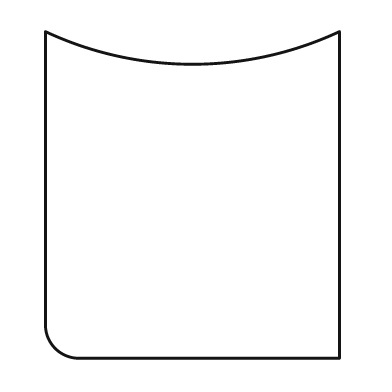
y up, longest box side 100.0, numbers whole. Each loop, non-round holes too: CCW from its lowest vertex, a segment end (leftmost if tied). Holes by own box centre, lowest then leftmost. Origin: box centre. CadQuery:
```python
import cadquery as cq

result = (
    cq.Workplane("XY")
    .moveTo(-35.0, -50.0)
    .lineTo(45.0, -50.0)
    .lineTo(45.0, 50.0)
    .threePointArc((0.0, 40.0), (-45.0, 50.0))
    .lineTo(-45.0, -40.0)
    .threePointArc((-42.0, -47.0), (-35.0, -50.0))
    .close()
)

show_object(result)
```